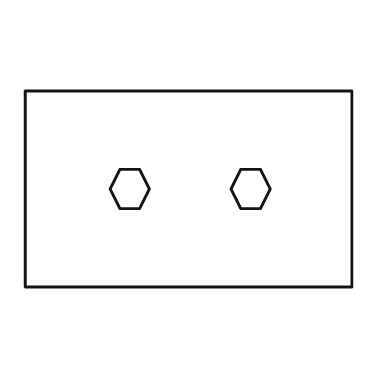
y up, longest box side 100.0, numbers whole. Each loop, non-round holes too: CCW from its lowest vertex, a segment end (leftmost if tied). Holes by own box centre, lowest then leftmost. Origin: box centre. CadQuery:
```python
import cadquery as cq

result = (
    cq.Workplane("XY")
    .moveTo(-50.0, -30.0)
    .lineTo(50.0, -30.0)
    .lineTo(50.0, 30.0)
    .lineTo(-50.0, 30.0)
    .close()
    .moveTo(-21.0, -6.0)
    .lineTo(-15.0, -6.0)
    .lineTo(-12.0, 0.0)
    .lineTo(-15.0, 6.0)
    .lineTo(-21.0, 6.0)
    .lineTo(-24.0, 0.0)
    .close()
    .moveTo(16.0, -6.0)
    .lineTo(22.0, -6.0)
    .lineTo(25.0, 0.0)
    .lineTo(22.0, 6.0)
    .lineTo(16.0, 6.0)
    .lineTo(13.0, 0.0)
    .close()
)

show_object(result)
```